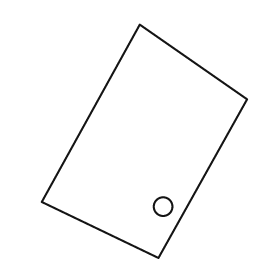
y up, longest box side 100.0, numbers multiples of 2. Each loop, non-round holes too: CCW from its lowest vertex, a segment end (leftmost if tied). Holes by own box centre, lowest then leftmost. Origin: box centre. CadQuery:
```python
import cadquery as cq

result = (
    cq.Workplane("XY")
    .moveTo(6.0, -50.0)
    .lineTo(44.0, 18.0)
    .lineTo(-2.0, 50.0)
    .lineTo(-44.0, -26.0)
    .close()
    .moveTo(8.0, -28.0)
    .circle(4.0)
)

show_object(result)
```